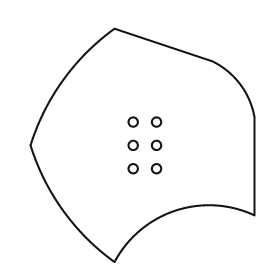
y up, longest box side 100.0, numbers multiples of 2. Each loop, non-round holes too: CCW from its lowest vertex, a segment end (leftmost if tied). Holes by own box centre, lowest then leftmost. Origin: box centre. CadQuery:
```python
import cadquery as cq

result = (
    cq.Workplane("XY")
    .moveTo(-12.0, -50.0)
    .threePointArc((14.0, -28.0), (48.0, -30.0))
    .lineTo(48.0, 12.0)
    .threePointArc((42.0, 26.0), (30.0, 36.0))
    .lineTo(-12.0, 50.0)
    .threePointArc((-34.0, 28.0), (-48.0, 0.0))
    .threePointArc((-34.0, -28.0), (-12.0, -50.0))
    .close()
    .moveTo(-4.0, -10.0)
    .circle(2.0)
    .moveTo(6.0, -10.0)
    .circle(2.0)
    .moveTo(-4.0, 0.0)
    .circle(2.0)
    .moveTo(6.0, 0.0)
    .circle(2.0)
    .moveTo(-4.0, 10.0)
    .circle(2.0)
    .moveTo(6.0, 10.0)
    .circle(2.0)
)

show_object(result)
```